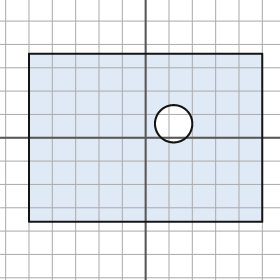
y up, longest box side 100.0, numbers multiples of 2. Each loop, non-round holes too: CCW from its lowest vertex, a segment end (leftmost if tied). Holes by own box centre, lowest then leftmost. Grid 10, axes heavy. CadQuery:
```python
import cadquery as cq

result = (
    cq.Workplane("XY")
    .moveTo(-50.0, -36.0)
    .lineTo(50.0, -36.0)
    .lineTo(50.0, 36.0)
    .lineTo(-50.0, 36.0)
    .close()
    .moveTo(12.0, 6.0)
    .circle(8.0)
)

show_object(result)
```